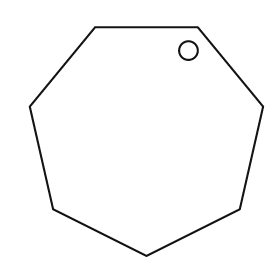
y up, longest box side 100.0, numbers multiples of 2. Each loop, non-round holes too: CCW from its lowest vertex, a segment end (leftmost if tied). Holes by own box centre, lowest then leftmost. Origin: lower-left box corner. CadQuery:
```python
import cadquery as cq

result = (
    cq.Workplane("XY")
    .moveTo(50.0, 0.0)
    .lineTo(90.0, 20.0)
    .lineTo(100.0, 64.0)
    .lineTo(72.0, 98.0)
    .lineTo(28.0, 98.0)
    .lineTo(0.0, 64.0)
    .lineTo(10.0, 20.0)
    .close()
    .moveTo(68.0, 88.0)
    .circle(4.0)
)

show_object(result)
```